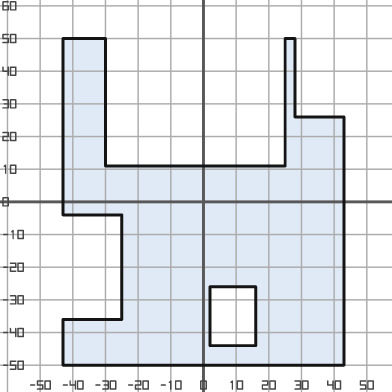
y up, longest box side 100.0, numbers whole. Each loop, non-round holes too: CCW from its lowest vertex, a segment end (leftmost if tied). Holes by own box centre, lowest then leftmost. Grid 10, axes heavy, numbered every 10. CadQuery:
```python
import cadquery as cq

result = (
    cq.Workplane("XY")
    .moveTo(-43.0, -50.0)
    .lineTo(43.0, -50.0)
    .lineTo(43.0, 26.0)
    .lineTo(28.0, 26.0)
    .lineTo(28.0, 50.0)
    .lineTo(25.0, 50.0)
    .lineTo(25.0, 11.0)
    .lineTo(-30.0, 11.0)
    .lineTo(-30.0, 50.0)
    .lineTo(-43.0, 50.0)
    .lineTo(-43.0, -4.0)
    .lineTo(-25.0, -4.0)
    .lineTo(-25.0, -36.0)
    .lineTo(-43.0, -36.0)
    .close()
    .moveTo(2.0, -44.0)
    .lineTo(16.0, -44.0)
    .lineTo(16.0, -26.0)
    .lineTo(2.0, -26.0)
    .close()
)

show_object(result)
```